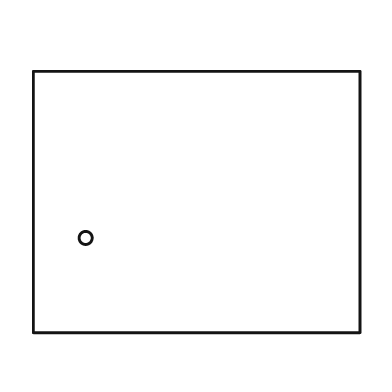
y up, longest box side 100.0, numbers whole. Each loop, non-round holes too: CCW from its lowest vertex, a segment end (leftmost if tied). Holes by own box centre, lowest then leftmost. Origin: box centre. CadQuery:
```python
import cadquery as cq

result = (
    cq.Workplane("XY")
    .moveTo(-50.0, -40.0)
    .lineTo(50.0, -40.0)
    .lineTo(50.0, 40.0)
    .lineTo(-50.0, 40.0)
    .close()
    .moveTo(-34.0, -11.0)
    .circle(2.0)
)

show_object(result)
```